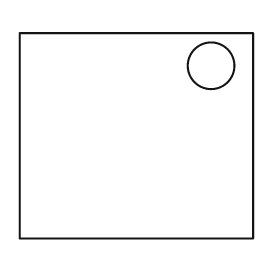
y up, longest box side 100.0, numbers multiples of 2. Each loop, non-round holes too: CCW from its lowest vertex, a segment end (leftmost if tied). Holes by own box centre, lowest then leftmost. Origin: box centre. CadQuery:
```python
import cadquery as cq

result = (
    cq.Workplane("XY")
    .moveTo(-50.0, -44.0)
    .lineTo(50.0, -44.0)
    .lineTo(50.0, 44.0)
    .lineTo(-50.0, 44.0)
    .close()
    .moveTo(32.0, 30.0)
    .circle(10.0)
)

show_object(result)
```